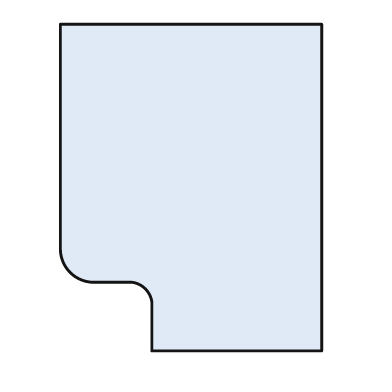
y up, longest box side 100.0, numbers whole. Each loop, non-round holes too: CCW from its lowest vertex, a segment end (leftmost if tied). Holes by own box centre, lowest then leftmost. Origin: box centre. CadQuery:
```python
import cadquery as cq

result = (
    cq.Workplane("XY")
    .moveTo(-12.0, -50.0)
    .lineTo(40.0, -50.0)
    .lineTo(40.0, 50.0)
    .lineTo(-40.0, 50.0)
    .lineTo(-40.0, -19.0)
    .threePointArc((-37.0, -26.0), (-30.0, -29.0))
    .lineTo(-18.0, -29.0)
    .threePointArc((-14.0, -31.0), (-12.0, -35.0))
    .close()
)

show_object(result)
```